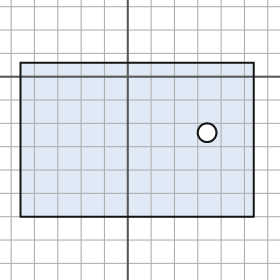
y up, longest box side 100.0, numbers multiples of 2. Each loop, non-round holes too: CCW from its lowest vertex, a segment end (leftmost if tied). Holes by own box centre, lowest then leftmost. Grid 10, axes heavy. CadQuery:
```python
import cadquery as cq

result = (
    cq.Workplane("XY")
    .moveTo(-46.0, -60.0)
    .lineTo(54.0, -60.0)
    .lineTo(54.0, 6.0)
    .lineTo(-46.0, 6.0)
    .close()
    .moveTo(34.0, -24.0)
    .circle(4.0)
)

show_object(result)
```